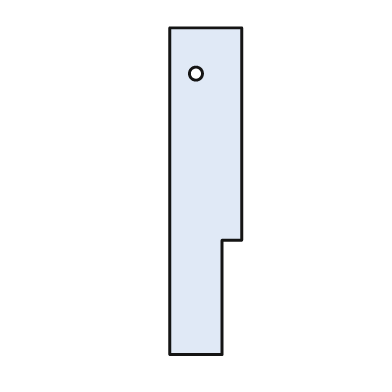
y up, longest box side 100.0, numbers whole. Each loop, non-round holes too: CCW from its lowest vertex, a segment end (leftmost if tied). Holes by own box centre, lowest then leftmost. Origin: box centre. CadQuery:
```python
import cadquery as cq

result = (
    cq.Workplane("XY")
    .moveTo(-11.0, -50.0)
    .lineTo(5.0, -50.0)
    .lineTo(5.0, -15.0)
    .lineTo(11.0, -15.0)
    .lineTo(11.0, 50.0)
    .lineTo(-11.0, 50.0)
    .close()
    .moveTo(-3.0, 36.0)
    .circle(2.0)
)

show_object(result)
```